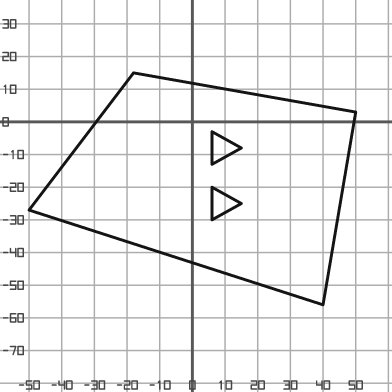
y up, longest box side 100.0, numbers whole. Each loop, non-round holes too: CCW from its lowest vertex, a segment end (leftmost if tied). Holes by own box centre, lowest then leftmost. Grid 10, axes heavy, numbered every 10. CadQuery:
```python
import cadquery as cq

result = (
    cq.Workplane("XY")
    .moveTo(40.0, -56.0)
    .lineTo(50.0, 3.0)
    .lineTo(-18.0, 15.0)
    .lineTo(-50.0, -27.0)
    .close()
    .moveTo(6.0, -30.0)
    .lineTo(15.0, -25.0)
    .lineTo(6.0, -20.0)
    .close()
    .moveTo(6.0, -13.0)
    .lineTo(15.0, -8.0)
    .lineTo(6.0, -3.0)
    .close()
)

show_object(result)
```